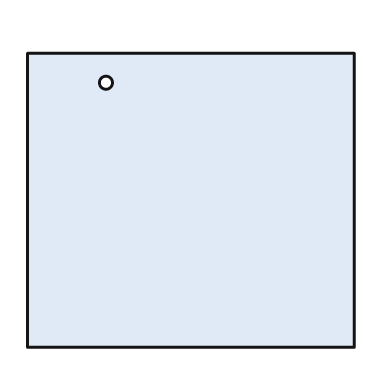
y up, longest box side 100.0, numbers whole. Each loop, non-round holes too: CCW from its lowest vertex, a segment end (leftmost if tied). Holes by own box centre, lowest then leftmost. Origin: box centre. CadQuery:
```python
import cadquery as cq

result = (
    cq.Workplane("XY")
    .moveTo(-50.0, -45.0)
    .lineTo(50.0, -45.0)
    .lineTo(50.0, 45.0)
    .lineTo(-50.0, 45.0)
    .close()
    .moveTo(-26.0, 36.0)
    .circle(2.0)
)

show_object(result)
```